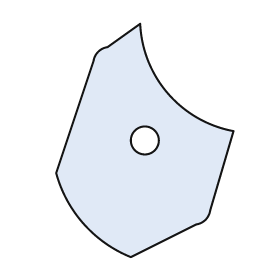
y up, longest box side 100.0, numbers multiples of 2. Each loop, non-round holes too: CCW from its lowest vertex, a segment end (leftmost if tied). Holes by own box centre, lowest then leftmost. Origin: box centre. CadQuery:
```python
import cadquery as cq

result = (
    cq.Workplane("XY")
    .moveTo(-6.0, -50.0)
    .lineTo(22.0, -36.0)
    .threePointArc((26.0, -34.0), (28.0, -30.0))
    .lineTo(38.0, 4.0)
    .threePointArc((10.0, 20.0), (-2.0, 50.0))
    .lineTo(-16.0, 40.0)
    .threePointArc((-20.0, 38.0), (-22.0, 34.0))
    .lineTo(-38.0, -14.0)
    .threePointArc((-26.0, -36.0), (-6.0, -50.0))
    .close()
    .moveTo(0.0, 0.0)
    .circle(6.0)
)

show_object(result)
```